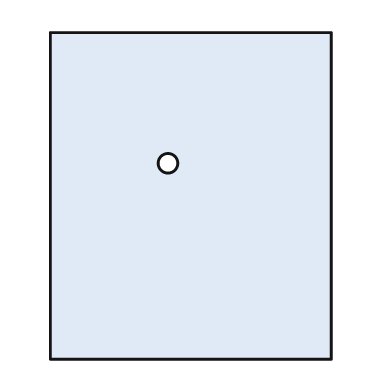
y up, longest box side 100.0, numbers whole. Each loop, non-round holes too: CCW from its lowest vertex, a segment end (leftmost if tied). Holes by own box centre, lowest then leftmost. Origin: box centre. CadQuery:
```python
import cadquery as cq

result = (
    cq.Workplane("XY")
    .moveTo(-43.0, -50.0)
    .lineTo(43.0, -50.0)
    .lineTo(43.0, 50.0)
    .lineTo(-43.0, 50.0)
    .close()
    .moveTo(-7.0, 10.0)
    .circle(3.0)
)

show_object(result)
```